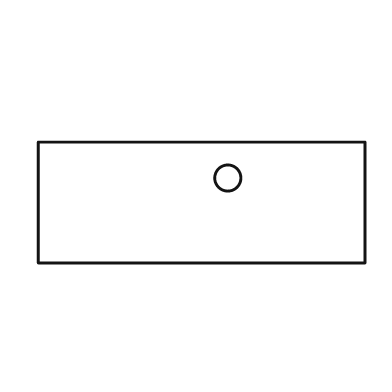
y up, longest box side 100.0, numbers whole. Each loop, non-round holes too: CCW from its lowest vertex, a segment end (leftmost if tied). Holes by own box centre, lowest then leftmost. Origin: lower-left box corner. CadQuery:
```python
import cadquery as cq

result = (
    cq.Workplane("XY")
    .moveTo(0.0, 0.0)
    .lineTo(100.0, 0.0)
    .lineTo(100.0, 37.0)
    .lineTo(0.0, 37.0)
    .close()
    .moveTo(58.0, 26.0)
    .circle(4.0)
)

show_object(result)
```